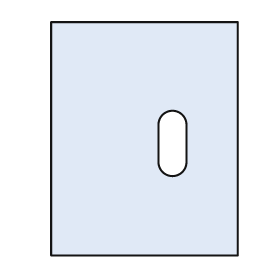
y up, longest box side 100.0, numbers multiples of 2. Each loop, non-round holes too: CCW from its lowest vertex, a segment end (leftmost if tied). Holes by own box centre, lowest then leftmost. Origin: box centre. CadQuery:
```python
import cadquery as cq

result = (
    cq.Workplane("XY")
    .moveTo(-40.0, -50.0)
    .lineTo(40.0, -50.0)
    .lineTo(40.0, 50.0)
    .lineTo(-40.0, 50.0)
    .close()
    .moveTo(6.0, -10.0)
    .threePointArc((12.0, -16.0), (18.0, -10.0))
    .lineTo(18.0, 6.0)
    .threePointArc((12.0, 12.0), (6.0, 6.0))
    .close()
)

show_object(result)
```